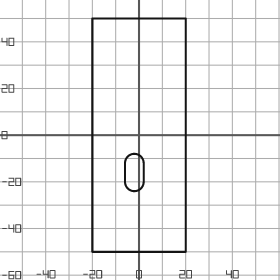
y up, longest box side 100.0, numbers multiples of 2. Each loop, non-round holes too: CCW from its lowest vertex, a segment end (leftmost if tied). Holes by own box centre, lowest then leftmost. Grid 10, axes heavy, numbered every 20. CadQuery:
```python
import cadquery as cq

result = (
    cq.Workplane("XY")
    .moveTo(-20.0, -50.0)
    .lineTo(20.0, -50.0)
    .lineTo(20.0, 50.0)
    .lineTo(-20.0, 50.0)
    .close()
    .moveTo(-6.0, -20.0)
    .threePointArc((-2.0, -24.0), (2.0, -20.0))
    .lineTo(2.0, -12.0)
    .threePointArc((-2.0, -8.0), (-6.0, -12.0))
    .close()
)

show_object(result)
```